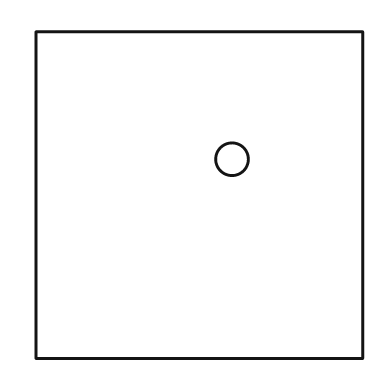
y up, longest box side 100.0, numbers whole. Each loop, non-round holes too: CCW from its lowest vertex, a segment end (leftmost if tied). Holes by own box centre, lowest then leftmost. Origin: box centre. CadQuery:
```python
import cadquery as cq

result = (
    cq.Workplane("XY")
    .moveTo(-50.0, -50.0)
    .lineTo(50.0, -50.0)
    .lineTo(50.0, 50.0)
    .lineTo(-50.0, 50.0)
    .close()
    .moveTo(10.0, 11.0)
    .circle(5.0)
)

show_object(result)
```